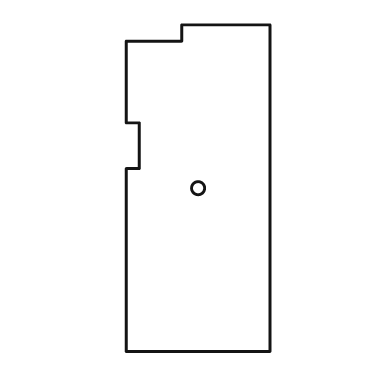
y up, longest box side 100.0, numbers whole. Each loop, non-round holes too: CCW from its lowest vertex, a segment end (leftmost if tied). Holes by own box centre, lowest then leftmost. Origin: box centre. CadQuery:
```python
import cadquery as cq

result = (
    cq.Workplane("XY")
    .moveTo(-22.0, -50.0)
    .lineTo(22.0, -50.0)
    .lineTo(22.0, 50.0)
    .lineTo(-5.0, 50.0)
    .lineTo(-5.0, 45.0)
    .lineTo(-22.0, 45.0)
    .lineTo(-22.0, 20.0)
    .lineTo(-18.0, 20.0)
    .lineTo(-18.0, 6.0)
    .lineTo(-22.0, 6.0)
    .close()
    .moveTo(0.0, 0.0)
    .circle(2.0)
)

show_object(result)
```